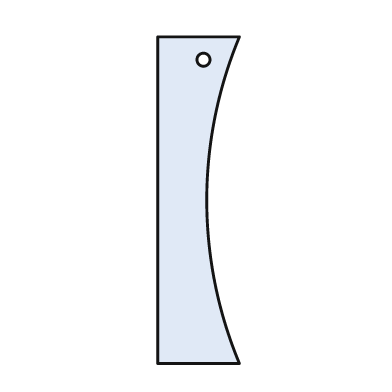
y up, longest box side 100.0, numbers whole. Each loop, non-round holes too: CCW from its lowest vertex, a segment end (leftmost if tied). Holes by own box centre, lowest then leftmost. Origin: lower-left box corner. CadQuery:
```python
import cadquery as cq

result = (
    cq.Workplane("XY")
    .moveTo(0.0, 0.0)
    .lineTo(25.0, 0.0)
    .threePointArc((15.0, 50.0), (25.0, 100.0))
    .lineTo(0.0, 100.0)
    .close()
    .moveTo(14.0, 93.0)
    .circle(2.0)
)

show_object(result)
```